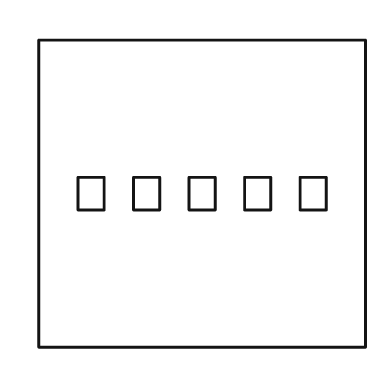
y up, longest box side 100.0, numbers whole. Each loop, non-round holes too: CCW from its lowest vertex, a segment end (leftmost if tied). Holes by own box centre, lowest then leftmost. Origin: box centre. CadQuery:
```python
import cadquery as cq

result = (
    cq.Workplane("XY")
    .moveTo(-50.0, -47.0)
    .lineTo(50.0, -47.0)
    .lineTo(50.0, 47.0)
    .lineTo(-50.0, 47.0)
    .close()
    .moveTo(-38.0, -5.0)
    .lineTo(-30.0, -5.0)
    .lineTo(-30.0, 5.0)
    .lineTo(-38.0, 5.0)
    .close()
    .moveTo(-21.0, -5.0)
    .lineTo(-13.0, -5.0)
    .lineTo(-13.0, 5.0)
    .lineTo(-21.0, 5.0)
    .close()
    .moveTo(-4.0, -5.0)
    .lineTo(4.0, -5.0)
    .lineTo(4.0, 5.0)
    .lineTo(-4.0, 5.0)
    .close()
    .moveTo(13.0, -5.0)
    .lineTo(21.0, -5.0)
    .lineTo(21.0, 5.0)
    .lineTo(13.0, 5.0)
    .close()
    .moveTo(30.0, -5.0)
    .lineTo(38.0, -5.0)
    .lineTo(38.0, 5.0)
    .lineTo(30.0, 5.0)
    .close()
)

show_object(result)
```